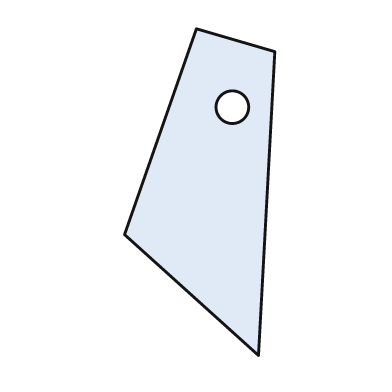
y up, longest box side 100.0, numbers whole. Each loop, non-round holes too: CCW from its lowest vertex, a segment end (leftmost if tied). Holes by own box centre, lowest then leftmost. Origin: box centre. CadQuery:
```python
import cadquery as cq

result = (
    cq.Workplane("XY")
    .moveTo(18.0, -50.0)
    .lineTo(23.0, 43.0)
    .lineTo(-1.0, 50.0)
    .lineTo(-23.0, -13.0)
    .close()
    .moveTo(10.0, 26.0)
    .circle(5.0)
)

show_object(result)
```